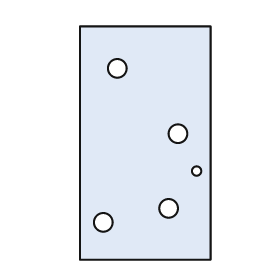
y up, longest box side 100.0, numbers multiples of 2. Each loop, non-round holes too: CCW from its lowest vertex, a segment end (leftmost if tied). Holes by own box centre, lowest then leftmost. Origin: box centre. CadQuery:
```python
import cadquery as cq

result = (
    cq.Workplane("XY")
    .moveTo(-28.0, -50.0)
    .lineTo(28.0, -50.0)
    .lineTo(28.0, 50.0)
    .lineTo(-28.0, 50.0)
    .close()
    .moveTo(-18.0, -34.0)
    .circle(4.0)
    .moveTo(10.0, -28.0)
    .circle(4.0)
    .moveTo(22.0, -12.0)
    .circle(2.0)
    .moveTo(14.0, 4.0)
    .circle(4.0)
    .moveTo(-12.0, 32.0)
    .circle(4.0)
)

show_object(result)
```